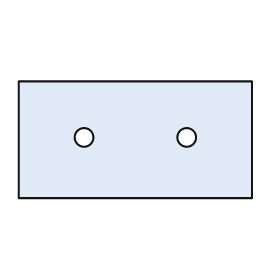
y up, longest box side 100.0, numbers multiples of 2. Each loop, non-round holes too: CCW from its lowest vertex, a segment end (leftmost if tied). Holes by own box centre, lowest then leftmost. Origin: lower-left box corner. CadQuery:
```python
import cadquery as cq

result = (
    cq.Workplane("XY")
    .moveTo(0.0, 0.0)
    .lineTo(100.0, 0.0)
    .lineTo(100.0, 50.0)
    .lineTo(0.0, 50.0)
    .close()
    .moveTo(28.0, 26.0)
    .circle(4.0)
    .moveTo(72.0, 26.0)
    .circle(4.0)
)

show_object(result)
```